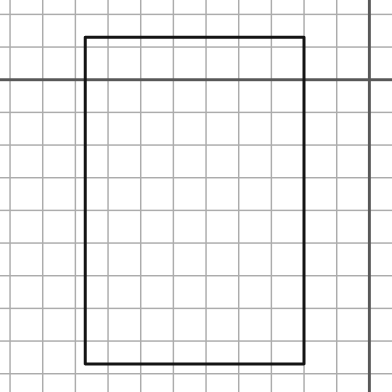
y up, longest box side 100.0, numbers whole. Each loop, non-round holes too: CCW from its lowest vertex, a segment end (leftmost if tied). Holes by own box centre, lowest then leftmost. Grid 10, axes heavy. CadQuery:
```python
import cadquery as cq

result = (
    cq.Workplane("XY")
    .moveTo(-87.0, -87.0)
    .lineTo(-20.0, -87.0)
    .lineTo(-20.0, 13.0)
    .lineTo(-87.0, 13.0)
    .close()
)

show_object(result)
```